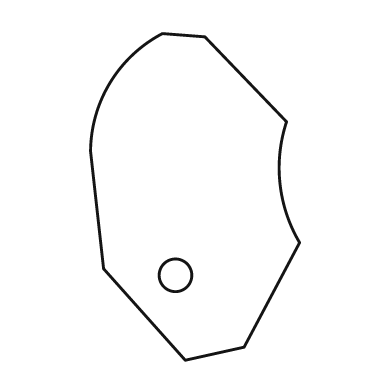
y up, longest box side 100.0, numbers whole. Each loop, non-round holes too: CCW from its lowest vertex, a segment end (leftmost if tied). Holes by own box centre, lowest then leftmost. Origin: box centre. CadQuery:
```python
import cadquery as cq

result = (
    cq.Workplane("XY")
    .moveTo(-3.0, -50.0)
    .lineTo(15.0, -46.0)
    .lineTo(32.0, -14.0)
    .threePointArc((26.0, 4.0), (28.0, 23.0))
    .lineTo(3.0, 49.0)
    .lineTo(-10.0, 50.0)
    .threePointArc((-26.0, 35.0), (-32.0, 14.0))
    .lineTo(-28.0, -22.0)
    .close()
    .moveTo(-6.0, -24.0)
    .circle(5.0)
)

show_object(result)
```